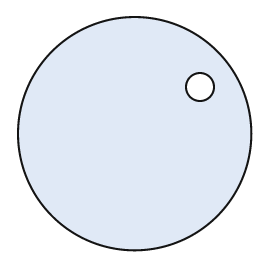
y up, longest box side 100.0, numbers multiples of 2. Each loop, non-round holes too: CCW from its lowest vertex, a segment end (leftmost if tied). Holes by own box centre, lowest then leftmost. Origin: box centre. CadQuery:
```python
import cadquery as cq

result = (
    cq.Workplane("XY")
    .moveTo(0.0, 0.0)
    .circle(50.0)
    .moveTo(28.0, 20.0)
    .circle(6.0)
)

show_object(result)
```